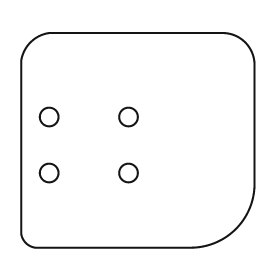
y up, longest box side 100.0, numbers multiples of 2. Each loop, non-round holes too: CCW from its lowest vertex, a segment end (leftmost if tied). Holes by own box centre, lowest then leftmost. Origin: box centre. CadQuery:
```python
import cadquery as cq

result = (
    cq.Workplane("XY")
    .moveTo(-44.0, -46.0)
    .lineTo(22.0, -46.0)
    .threePointArc((42.0, -38.0), (50.0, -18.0))
    .lineTo(50.0, 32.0)
    .threePointArc((46.0, 42.0), (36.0, 46.0))
    .lineTo(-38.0, 46.0)
    .threePointArc((-46.0, 42.0), (-50.0, 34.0))
    .lineTo(-50.0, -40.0)
    .threePointArc((-48.0, -44.0), (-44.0, -46.0))
    .close()
    .moveTo(-38.0, -14.0)
    .circle(4.0)
    .moveTo(-4.0, -14.0)
    .circle(4.0)
    .moveTo(-38.0, 10.0)
    .circle(4.0)
    .moveTo(-4.0, 10.0)
    .circle(4.0)
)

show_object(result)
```